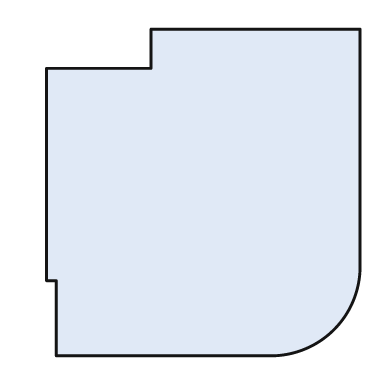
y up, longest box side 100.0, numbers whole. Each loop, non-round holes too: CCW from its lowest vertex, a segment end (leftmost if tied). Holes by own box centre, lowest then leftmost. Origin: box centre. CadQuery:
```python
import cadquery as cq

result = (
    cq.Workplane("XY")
    .moveTo(-45.0, -50.0)
    .lineTo(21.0, -50.0)
    .threePointArc((40.0, -42.0), (48.0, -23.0))
    .lineTo(48.0, 50.0)
    .lineTo(-16.0, 50.0)
    .lineTo(-16.0, 38.0)
    .lineTo(-48.0, 38.0)
    .lineTo(-48.0, -27.0)
    .lineTo(-45.0, -27.0)
    .close()
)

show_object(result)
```